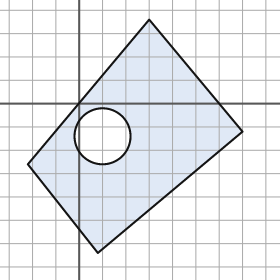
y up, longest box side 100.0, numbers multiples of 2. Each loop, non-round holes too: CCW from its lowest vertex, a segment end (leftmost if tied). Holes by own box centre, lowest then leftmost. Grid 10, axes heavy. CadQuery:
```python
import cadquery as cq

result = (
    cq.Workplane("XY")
    .moveTo(8.0, -64.0)
    .lineTo(70.0, -12.0)
    .lineTo(30.0, 36.0)
    .lineTo(-22.0, -26.0)
    .close()
    .moveTo(10.0, -14.0)
    .circle(12.0)
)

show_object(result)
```